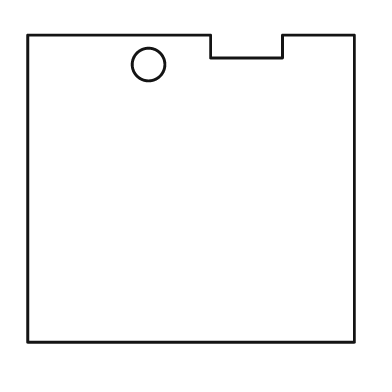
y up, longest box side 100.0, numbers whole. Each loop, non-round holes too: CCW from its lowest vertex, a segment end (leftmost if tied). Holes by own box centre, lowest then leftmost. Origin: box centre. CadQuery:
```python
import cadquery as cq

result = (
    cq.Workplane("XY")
    .moveTo(-50.0, -47.0)
    .lineTo(50.0, -47.0)
    .lineTo(50.0, 47.0)
    .lineTo(28.0, 47.0)
    .lineTo(28.0, 40.0)
    .lineTo(6.0, 40.0)
    .lineTo(6.0, 47.0)
    .lineTo(-50.0, 47.0)
    .close()
    .moveTo(-13.0, 38.0)
    .circle(5.0)
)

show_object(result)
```